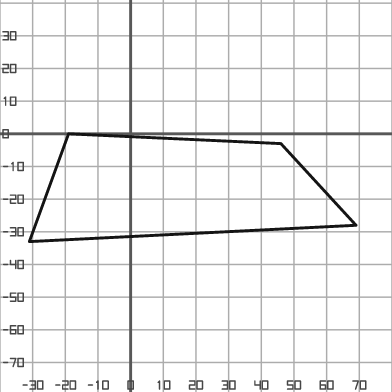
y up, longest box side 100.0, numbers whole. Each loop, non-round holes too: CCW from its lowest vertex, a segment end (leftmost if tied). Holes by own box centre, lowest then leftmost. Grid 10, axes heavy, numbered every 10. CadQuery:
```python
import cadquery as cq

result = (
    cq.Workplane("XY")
    .moveTo(-31.0, -33.0)
    .lineTo(69.0, -28.0)
    .lineTo(46.0, -3.0)
    .lineTo(-19.0, 0.0)
    .close()
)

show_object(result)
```